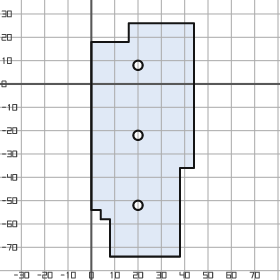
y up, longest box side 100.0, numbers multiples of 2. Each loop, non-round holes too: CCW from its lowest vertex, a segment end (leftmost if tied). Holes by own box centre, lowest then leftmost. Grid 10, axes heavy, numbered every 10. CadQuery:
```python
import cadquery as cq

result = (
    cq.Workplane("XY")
    .moveTo(8.0, -74.0)
    .lineTo(38.0, -74.0)
    .lineTo(38.0, -36.0)
    .lineTo(44.0, -36.0)
    .lineTo(44.0, 26.0)
    .lineTo(16.0, 26.0)
    .lineTo(16.0, 18.0)
    .lineTo(0.0, 18.0)
    .lineTo(0.0, -54.0)
    .lineTo(4.0, -54.0)
    .lineTo(4.0, -58.0)
    .lineTo(8.0, -58.0)
    .close()
    .moveTo(20.0, -52.0)
    .circle(2.0)
    .moveTo(20.0, -22.0)
    .circle(2.0)
    .moveTo(20.0, 8.0)
    .circle(2.0)
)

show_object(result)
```